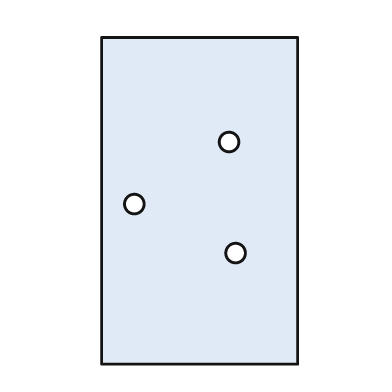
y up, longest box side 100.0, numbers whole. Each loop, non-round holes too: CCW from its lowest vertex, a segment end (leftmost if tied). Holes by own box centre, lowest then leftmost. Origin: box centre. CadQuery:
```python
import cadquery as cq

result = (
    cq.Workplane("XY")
    .moveTo(-30.0, -50.0)
    .lineTo(30.0, -50.0)
    .lineTo(30.0, 50.0)
    .lineTo(-30.0, 50.0)
    .close()
    .moveTo(11.0, -16.0)
    .circle(3.0)
    .moveTo(-20.0, -1.0)
    .circle(3.0)
    .moveTo(9.0, 18.0)
    .circle(3.0)
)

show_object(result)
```